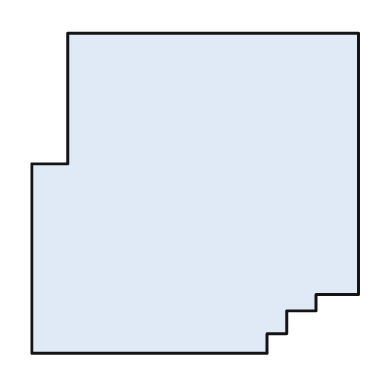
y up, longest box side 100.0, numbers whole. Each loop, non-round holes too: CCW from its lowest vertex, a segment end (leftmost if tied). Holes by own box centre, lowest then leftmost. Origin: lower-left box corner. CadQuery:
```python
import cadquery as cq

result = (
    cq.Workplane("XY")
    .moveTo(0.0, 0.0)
    .lineTo(72.0, 0.0)
    .lineTo(72.0, 6.0)
    .lineTo(78.0, 6.0)
    .lineTo(78.0, 13.0)
    .lineTo(87.0, 13.0)
    .lineTo(87.0, 18.0)
    .lineTo(100.0, 18.0)
    .lineTo(100.0, 98.0)
    .lineTo(11.0, 98.0)
    .lineTo(11.0, 58.0)
    .lineTo(0.0, 58.0)
    .close()
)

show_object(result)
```